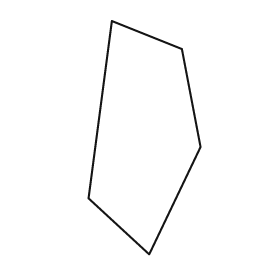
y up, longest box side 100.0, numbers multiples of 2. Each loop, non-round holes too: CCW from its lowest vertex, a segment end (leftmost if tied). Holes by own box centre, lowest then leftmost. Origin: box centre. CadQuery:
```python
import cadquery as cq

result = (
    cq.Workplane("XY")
    .moveTo(2.0, -50.0)
    .lineTo(24.0, -4.0)
    .lineTo(16.0, 38.0)
    .lineTo(-14.0, 50.0)
    .lineTo(-24.0, -26.0)
    .close()
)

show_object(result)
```